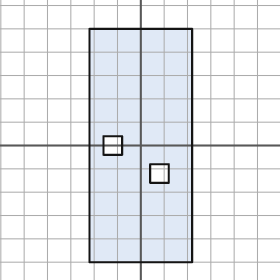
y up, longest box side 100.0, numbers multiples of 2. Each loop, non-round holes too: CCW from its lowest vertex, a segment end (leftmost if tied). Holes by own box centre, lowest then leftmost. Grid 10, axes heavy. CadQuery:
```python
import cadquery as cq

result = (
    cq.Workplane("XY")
    .moveTo(-22.0, -50.0)
    .lineTo(22.0, -50.0)
    .lineTo(22.0, 50.0)
    .lineTo(-22.0, 50.0)
    .close()
    .moveTo(4.0, -16.0)
    .lineTo(12.0, -16.0)
    .lineTo(12.0, -8.0)
    .lineTo(4.0, -8.0)
    .close()
    .moveTo(-16.0, -4.0)
    .lineTo(-8.0, -4.0)
    .lineTo(-8.0, 4.0)
    .lineTo(-16.0, 4.0)
    .close()
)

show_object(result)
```